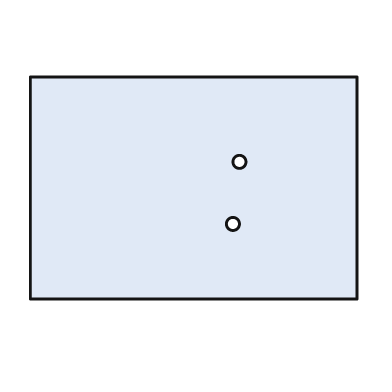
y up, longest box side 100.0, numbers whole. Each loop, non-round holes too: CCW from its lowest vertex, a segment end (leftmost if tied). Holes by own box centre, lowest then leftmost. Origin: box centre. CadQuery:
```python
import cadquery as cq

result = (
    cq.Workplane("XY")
    .moveTo(-50.0, -34.0)
    .lineTo(50.0, -34.0)
    .lineTo(50.0, 34.0)
    .lineTo(-50.0, 34.0)
    .close()
    .moveTo(12.0, -11.0)
    .circle(2.0)
    .moveTo(14.0, 8.0)
    .circle(2.0)
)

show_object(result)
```